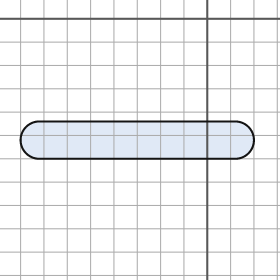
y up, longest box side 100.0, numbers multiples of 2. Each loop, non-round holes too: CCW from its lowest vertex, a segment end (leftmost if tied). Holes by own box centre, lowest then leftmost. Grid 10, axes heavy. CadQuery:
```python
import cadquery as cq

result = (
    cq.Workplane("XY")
    .moveTo(-72.0, -60.0)
    .lineTo(12.0, -60.0)
    .threePointArc((20.0, -52.0), (12.0, -44.0))
    .lineTo(-72.0, -44.0)
    .threePointArc((-80.0, -52.0), (-72.0, -60.0))
    .close()
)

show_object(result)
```